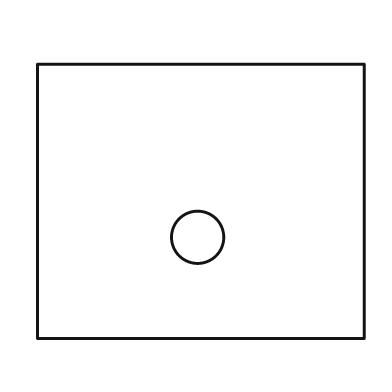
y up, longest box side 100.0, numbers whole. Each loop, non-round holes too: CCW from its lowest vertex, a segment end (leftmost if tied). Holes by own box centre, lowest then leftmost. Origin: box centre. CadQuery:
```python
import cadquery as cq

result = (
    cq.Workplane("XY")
    .moveTo(-50.0, -42.0)
    .lineTo(50.0, -42.0)
    .lineTo(50.0, 42.0)
    .lineTo(-50.0, 42.0)
    .close()
    .moveTo(-1.0, -11.0)
    .circle(8.0)
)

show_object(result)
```